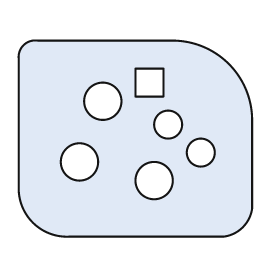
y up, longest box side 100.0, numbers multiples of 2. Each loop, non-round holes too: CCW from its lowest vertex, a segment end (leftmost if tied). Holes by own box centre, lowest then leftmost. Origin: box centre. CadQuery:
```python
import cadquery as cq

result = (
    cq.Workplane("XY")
    .moveTo(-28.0, -42.0)
    .lineTo(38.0, -42.0)
    .threePointArc((46.0, -38.0), (50.0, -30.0))
    .lineTo(50.0, 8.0)
    .threePointArc((40.0, 32.0), (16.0, 42.0))
    .lineTo(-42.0, 42.0)
    .threePointArc((-48.0, 40.0), (-50.0, 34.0))
    .lineTo(-50.0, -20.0)
    .threePointArc((-44.0, -36.0), (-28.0, -42.0))
    .close()
    .moveTo(8.0, -18.0)
    .circle(8.0)
    .moveTo(-24.0, -10.0)
    .circle(8.0)
    .moveTo(28.0, -6.0)
    .circle(6.0)
    .moveTo(14.0, 6.0)
    .circle(6.0)
    .moveTo(-14.0, 16.0)
    .circle(8.0)
    .moveTo(0.0, 18.0)
    .lineTo(12.0, 18.0)
    .lineTo(12.0, 30.0)
    .lineTo(0.0, 30.0)
    .close()
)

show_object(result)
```